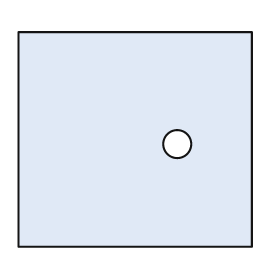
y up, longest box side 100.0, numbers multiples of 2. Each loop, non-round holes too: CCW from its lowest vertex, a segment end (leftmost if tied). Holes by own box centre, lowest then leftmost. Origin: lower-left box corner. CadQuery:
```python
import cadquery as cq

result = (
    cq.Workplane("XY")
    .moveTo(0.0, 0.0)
    .lineTo(100.0, 0.0)
    .lineTo(100.0, 92.0)
    .lineTo(0.0, 92.0)
    .close()
    .moveTo(68.0, 44.0)
    .circle(6.0)
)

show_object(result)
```